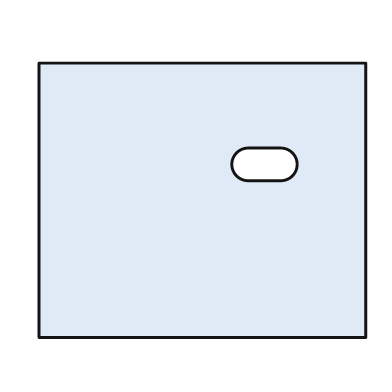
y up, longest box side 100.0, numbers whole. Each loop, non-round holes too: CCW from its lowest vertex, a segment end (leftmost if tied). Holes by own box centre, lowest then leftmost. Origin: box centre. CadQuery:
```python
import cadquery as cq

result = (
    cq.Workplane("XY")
    .moveTo(-50.0, -42.0)
    .lineTo(50.0, -42.0)
    .lineTo(50.0, 42.0)
    .lineTo(-50.0, 42.0)
    .close()
    .moveTo(14.0, 6.0)
    .lineTo(24.0, 6.0)
    .threePointArc((29.0, 11.0), (24.0, 16.0))
    .lineTo(14.0, 16.0)
    .threePointArc((9.0, 11.0), (14.0, 6.0))
    .close()
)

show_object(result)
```